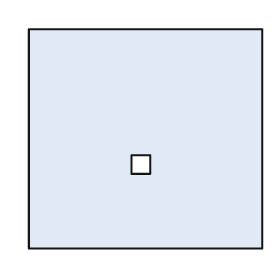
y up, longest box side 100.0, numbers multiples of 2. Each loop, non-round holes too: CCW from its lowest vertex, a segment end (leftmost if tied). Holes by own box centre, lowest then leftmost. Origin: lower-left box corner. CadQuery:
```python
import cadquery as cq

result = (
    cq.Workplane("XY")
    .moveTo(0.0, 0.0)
    .lineTo(100.0, 0.0)
    .lineTo(100.0, 94.0)
    .lineTo(0.0, 94.0)
    .close()
    .moveTo(44.0, 32.0)
    .lineTo(52.0, 32.0)
    .lineTo(52.0, 40.0)
    .lineTo(44.0, 40.0)
    .close()
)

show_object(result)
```